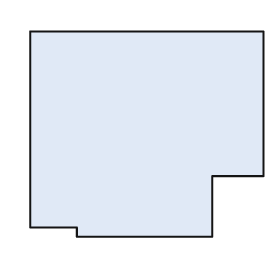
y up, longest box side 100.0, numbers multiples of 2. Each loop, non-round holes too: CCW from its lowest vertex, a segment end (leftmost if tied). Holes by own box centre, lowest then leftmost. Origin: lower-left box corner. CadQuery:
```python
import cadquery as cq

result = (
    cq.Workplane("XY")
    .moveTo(20.0, 0.0)
    .lineTo(78.0, 0.0)
    .lineTo(78.0, 26.0)
    .lineTo(100.0, 26.0)
    .lineTo(100.0, 88.0)
    .lineTo(0.0, 88.0)
    .lineTo(0.0, 4.0)
    .lineTo(20.0, 4.0)
    .close()
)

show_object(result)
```